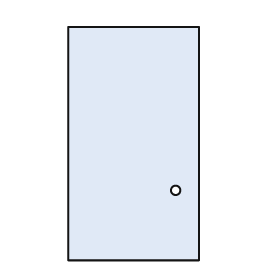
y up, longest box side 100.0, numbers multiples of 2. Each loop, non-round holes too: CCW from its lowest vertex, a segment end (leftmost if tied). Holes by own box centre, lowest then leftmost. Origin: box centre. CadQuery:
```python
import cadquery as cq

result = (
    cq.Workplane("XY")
    .moveTo(-28.0, -50.0)
    .lineTo(28.0, -50.0)
    .lineTo(28.0, 50.0)
    .lineTo(-28.0, 50.0)
    .close()
    .moveTo(18.0, -20.0)
    .circle(2.0)
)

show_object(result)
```